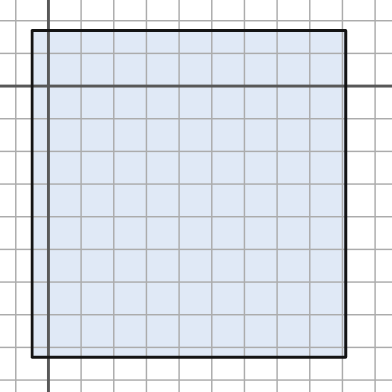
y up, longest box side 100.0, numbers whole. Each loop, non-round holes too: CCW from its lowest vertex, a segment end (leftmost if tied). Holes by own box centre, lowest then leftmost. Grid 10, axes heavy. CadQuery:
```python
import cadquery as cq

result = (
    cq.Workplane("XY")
    .moveTo(-5.0, -83.0)
    .lineTo(91.0, -83.0)
    .lineTo(91.0, 17.0)
    .lineTo(-5.0, 17.0)
    .close()
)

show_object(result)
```